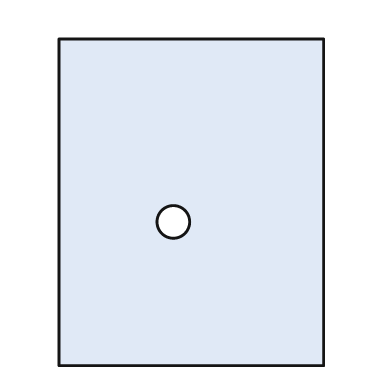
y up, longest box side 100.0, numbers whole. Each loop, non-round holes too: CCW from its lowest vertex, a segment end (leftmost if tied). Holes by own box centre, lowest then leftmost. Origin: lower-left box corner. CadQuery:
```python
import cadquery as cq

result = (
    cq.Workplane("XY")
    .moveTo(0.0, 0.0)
    .lineTo(81.0, 0.0)
    .lineTo(81.0, 100.0)
    .lineTo(0.0, 100.0)
    .close()
    .moveTo(35.0, 44.0)
    .circle(5.0)
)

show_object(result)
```